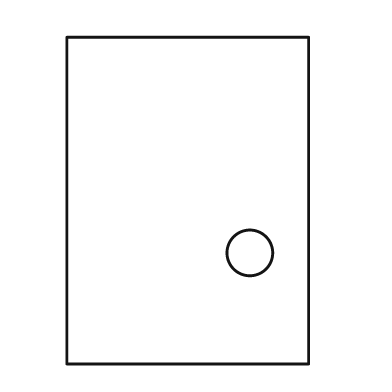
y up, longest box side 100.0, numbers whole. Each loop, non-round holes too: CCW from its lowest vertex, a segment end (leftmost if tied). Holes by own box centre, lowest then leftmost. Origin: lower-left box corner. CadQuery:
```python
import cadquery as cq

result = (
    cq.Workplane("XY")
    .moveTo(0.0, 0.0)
    .lineTo(74.0, 0.0)
    .lineTo(74.0, 100.0)
    .lineTo(0.0, 100.0)
    .close()
    .moveTo(56.0, 34.0)
    .circle(7.0)
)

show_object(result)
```